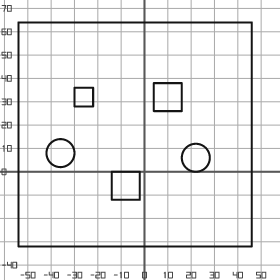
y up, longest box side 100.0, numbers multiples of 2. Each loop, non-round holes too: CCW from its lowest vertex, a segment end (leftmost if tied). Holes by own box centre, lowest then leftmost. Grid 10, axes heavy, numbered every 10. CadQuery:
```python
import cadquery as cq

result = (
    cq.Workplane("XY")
    .moveTo(-54.0, -32.0)
    .lineTo(46.0, -32.0)
    .lineTo(46.0, 64.0)
    .lineTo(-54.0, 64.0)
    .close()
    .moveTo(-14.0, -12.0)
    .lineTo(-2.0, -12.0)
    .lineTo(-2.0, 0.0)
    .lineTo(-14.0, 0.0)
    .close()
    .moveTo(22.0, 6.0)
    .circle(6.0)
    .moveTo(-36.0, 8.0)
    .circle(6.0)
    .moveTo(-30.0, 28.0)
    .lineTo(-22.0, 28.0)
    .lineTo(-22.0, 36.0)
    .lineTo(-30.0, 36.0)
    .close()
    .moveTo(4.0, 26.0)
    .lineTo(16.0, 26.0)
    .lineTo(16.0, 38.0)
    .lineTo(4.0, 38.0)
    .close()
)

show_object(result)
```